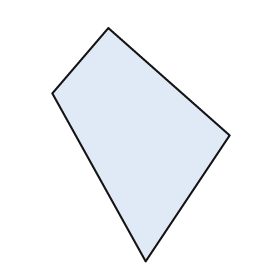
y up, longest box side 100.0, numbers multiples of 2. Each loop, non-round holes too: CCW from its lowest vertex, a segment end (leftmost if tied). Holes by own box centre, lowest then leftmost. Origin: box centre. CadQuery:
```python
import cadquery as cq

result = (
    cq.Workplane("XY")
    .moveTo(2.0, -50.0)
    .lineTo(38.0, 4.0)
    .lineTo(-14.0, 50.0)
    .lineTo(-38.0, 22.0)
    .close()
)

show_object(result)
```